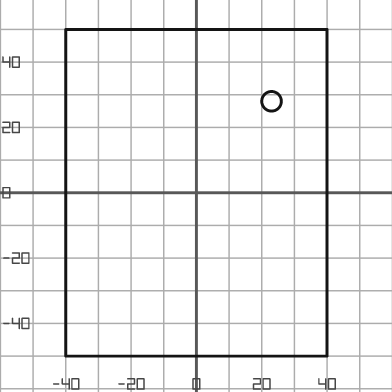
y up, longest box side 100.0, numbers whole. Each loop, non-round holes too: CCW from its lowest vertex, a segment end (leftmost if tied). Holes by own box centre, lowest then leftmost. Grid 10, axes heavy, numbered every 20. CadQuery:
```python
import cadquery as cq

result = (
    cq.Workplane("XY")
    .moveTo(-40.0, -50.0)
    .lineTo(40.0, -50.0)
    .lineTo(40.0, 50.0)
    .lineTo(-40.0, 50.0)
    .close()
    .moveTo(23.0, 28.0)
    .circle(3.0)
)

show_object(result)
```